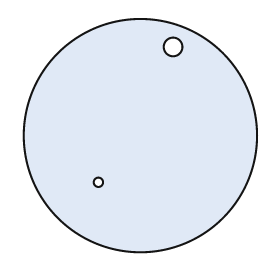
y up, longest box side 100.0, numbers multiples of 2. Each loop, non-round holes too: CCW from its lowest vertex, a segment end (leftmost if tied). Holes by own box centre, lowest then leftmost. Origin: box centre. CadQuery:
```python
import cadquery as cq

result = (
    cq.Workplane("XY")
    .moveTo(0.0, 0.0)
    .circle(50.0)
    .moveTo(-18.0, -20.0)
    .circle(2.0)
    .moveTo(14.0, 38.0)
    .circle(4.0)
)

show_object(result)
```